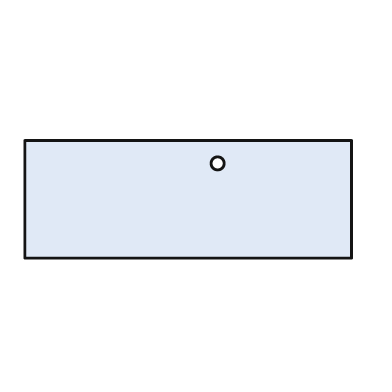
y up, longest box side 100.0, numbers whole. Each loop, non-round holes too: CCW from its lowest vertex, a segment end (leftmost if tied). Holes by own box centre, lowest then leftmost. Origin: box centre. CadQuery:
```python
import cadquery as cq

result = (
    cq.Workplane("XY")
    .moveTo(-50.0, -18.0)
    .lineTo(50.0, -18.0)
    .lineTo(50.0, 18.0)
    .lineTo(-50.0, 18.0)
    .close()
    .moveTo(9.0, 11.0)
    .circle(2.0)
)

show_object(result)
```